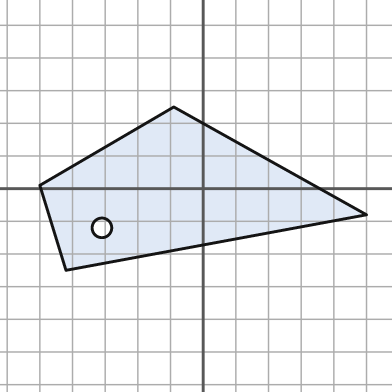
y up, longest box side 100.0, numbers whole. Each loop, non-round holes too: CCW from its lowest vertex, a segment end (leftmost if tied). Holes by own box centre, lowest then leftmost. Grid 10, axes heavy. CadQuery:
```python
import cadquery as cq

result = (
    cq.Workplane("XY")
    .moveTo(-42.0, -25.0)
    .lineTo(50.0, -8.0)
    .lineTo(-9.0, 25.0)
    .lineTo(-50.0, 1.0)
    .close()
    .moveTo(-31.0, -12.0)
    .circle(3.0)
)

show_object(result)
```